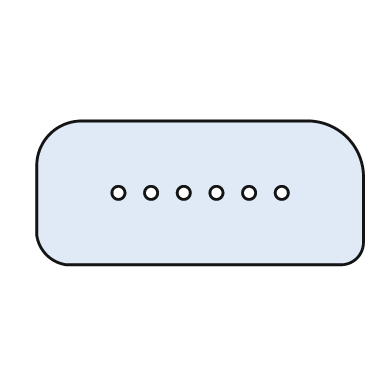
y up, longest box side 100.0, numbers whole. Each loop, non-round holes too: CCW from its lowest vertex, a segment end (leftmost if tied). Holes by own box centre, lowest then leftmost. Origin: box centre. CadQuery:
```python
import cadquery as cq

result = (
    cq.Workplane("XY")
    .moveTo(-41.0, -22.0)
    .lineTo(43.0, -22.0)
    .threePointArc((48.0, -20.0), (50.0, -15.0))
    .lineTo(50.0, 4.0)
    .threePointArc((45.0, 17.0), (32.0, 22.0))
    .lineTo(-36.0, 22.0)
    .threePointArc((-46.0, 18.0), (-50.0, 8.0))
    .lineTo(-50.0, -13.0)
    .threePointArc((-47.0, -19.0), (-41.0, -22.0))
    .close()
    .moveTo(-25.0, 0.0)
    .circle(2.0)
    .moveTo(-15.0, 0.0)
    .circle(2.0)
    .moveTo(-5.0, 0.0)
    .circle(2.0)
    .moveTo(5.0, 0.0)
    .circle(2.0)
    .moveTo(15.0, 0.0)
    .circle(2.0)
    .moveTo(25.0, 0.0)
    .circle(2.0)
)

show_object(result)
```